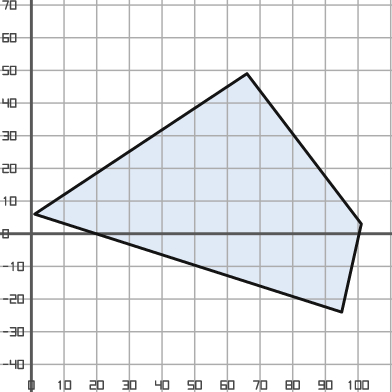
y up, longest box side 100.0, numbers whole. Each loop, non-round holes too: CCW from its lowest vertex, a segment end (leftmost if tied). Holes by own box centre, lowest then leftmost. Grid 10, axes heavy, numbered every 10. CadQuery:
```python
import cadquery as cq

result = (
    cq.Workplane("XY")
    .moveTo(95.0, -24.0)
    .lineTo(101.0, 3.0)
    .lineTo(66.0, 49.0)
    .lineTo(1.0, 6.0)
    .close()
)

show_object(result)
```